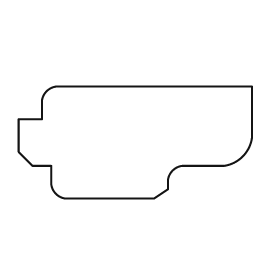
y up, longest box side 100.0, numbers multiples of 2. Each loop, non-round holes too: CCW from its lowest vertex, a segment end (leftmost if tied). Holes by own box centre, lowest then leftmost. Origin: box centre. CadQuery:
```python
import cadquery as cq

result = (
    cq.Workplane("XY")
    .moveTo(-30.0, -24.0)
    .lineTo(8.0, -24.0)
    .lineTo(14.0, -20.0)
    .lineTo(14.0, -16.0)
    .threePointArc((16.0, -12.0), (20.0, -10.0))
    .lineTo(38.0, -10.0)
    .threePointArc((46.0, -6.0), (50.0, 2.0))
    .lineTo(50.0, 24.0)
    .lineTo(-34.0, 24.0)
    .threePointArc((-38.0, 22.0), (-40.0, 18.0))
    .lineTo(-40.0, 10.0)
    .lineTo(-50.0, 10.0)
    .lineTo(-50.0, -4.0)
    .lineTo(-44.0, -10.0)
    .lineTo(-36.0, -10.0)
    .lineTo(-36.0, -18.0)
    .threePointArc((-34.0, -22.0), (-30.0, -24.0))
    .close()
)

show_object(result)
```